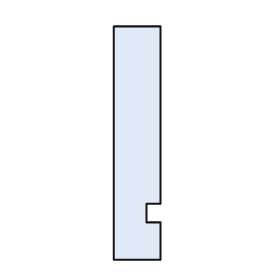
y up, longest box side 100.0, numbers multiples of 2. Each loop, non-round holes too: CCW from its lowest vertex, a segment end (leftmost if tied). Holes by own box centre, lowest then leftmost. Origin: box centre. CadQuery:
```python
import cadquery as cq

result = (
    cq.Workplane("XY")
    .moveTo(-10.0, -50.0)
    .lineTo(10.0, -50.0)
    .lineTo(10.0, -34.0)
    .lineTo(4.0, -34.0)
    .lineTo(4.0, -26.0)
    .lineTo(10.0, -26.0)
    .lineTo(10.0, 50.0)
    .lineTo(-10.0, 50.0)
    .close()
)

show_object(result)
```